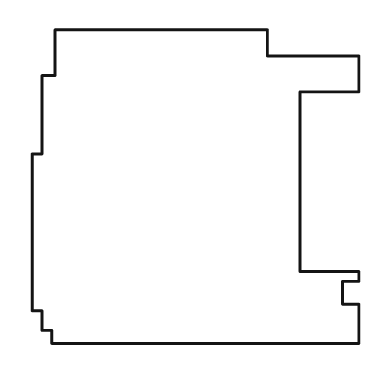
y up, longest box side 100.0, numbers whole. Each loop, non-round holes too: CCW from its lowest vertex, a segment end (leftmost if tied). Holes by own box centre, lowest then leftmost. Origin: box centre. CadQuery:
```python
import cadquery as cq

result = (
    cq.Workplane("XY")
    .moveTo(-44.0, -48.0)
    .lineTo(50.0, -48.0)
    .lineTo(50.0, -36.0)
    .lineTo(45.0, -36.0)
    .lineTo(45.0, -29.0)
    .lineTo(50.0, -29.0)
    .lineTo(50.0, -26.0)
    .lineTo(32.0, -26.0)
    .lineTo(32.0, 29.0)
    .lineTo(50.0, 29.0)
    .lineTo(50.0, 40.0)
    .lineTo(22.0, 40.0)
    .lineTo(22.0, 48.0)
    .lineTo(-43.0, 48.0)
    .lineTo(-43.0, 34.0)
    .lineTo(-47.0, 34.0)
    .lineTo(-47.0, 10.0)
    .lineTo(-50.0, 10.0)
    .lineTo(-50.0, -38.0)
    .lineTo(-47.0, -38.0)
    .lineTo(-47.0, -44.0)
    .lineTo(-44.0, -44.0)
    .close()
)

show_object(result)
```